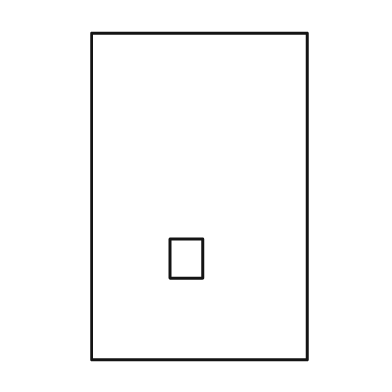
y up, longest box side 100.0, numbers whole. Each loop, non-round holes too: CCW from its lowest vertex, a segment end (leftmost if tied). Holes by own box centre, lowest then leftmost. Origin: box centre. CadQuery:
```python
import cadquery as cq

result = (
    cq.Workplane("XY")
    .moveTo(-33.0, -50.0)
    .lineTo(33.0, -50.0)
    .lineTo(33.0, 50.0)
    .lineTo(-33.0, 50.0)
    .close()
    .moveTo(-9.0, -25.0)
    .lineTo(1.0, -25.0)
    .lineTo(1.0, -13.0)
    .lineTo(-9.0, -13.0)
    .close()
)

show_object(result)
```